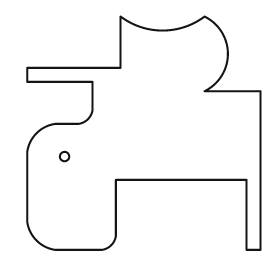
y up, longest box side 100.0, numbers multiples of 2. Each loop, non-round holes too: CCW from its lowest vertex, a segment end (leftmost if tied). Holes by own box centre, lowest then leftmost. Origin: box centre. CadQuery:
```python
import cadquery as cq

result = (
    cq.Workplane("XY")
    .moveTo(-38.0, -50.0)
    .lineTo(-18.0, -50.0)
    .threePointArc((-14.0, -48.0), (-12.0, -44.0))
    .lineTo(-12.0, -20.0)
    .lineTo(44.0, -20.0)
    .lineTo(44.0, -50.0)
    .lineTo(50.0, -50.0)
    .lineTo(50.0, 18.0)
    .lineTo(26.0, 18.0)
    .threePointArc((36.0, 34.0), (26.0, 50.0))
    .threePointArc((8.0, 44.0), (-10.0, 50.0))
    .lineTo(-10.0, 28.0)
    .lineTo(-50.0, 28.0)
    .lineTo(-50.0, 22.0)
    .lineTo(-22.0, 22.0)
    .lineTo(-22.0, 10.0)
    .threePointArc((-24.0, 6.0), (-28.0, 4.0))
    .lineTo(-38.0, 4.0)
    .threePointArc((-46.0, 0.0), (-50.0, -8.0))
    .lineTo(-50.0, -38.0)
    .threePointArc((-46.0, -46.0), (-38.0, -50.0))
    .close()
    .moveTo(-34.0, -10.0)
    .circle(2.0)
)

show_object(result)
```